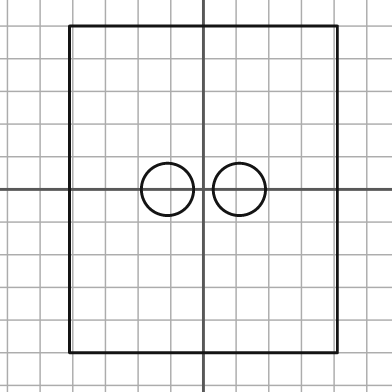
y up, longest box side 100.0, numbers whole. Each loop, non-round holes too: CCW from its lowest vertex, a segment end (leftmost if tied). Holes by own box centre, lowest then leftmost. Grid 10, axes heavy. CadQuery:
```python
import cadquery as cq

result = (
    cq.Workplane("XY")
    .moveTo(-41.0, -50.0)
    .lineTo(41.0, -50.0)
    .lineTo(41.0, 50.0)
    .lineTo(-41.0, 50.0)
    .close()
    .moveTo(-11.0, 0.0)
    .circle(8.0)
    .moveTo(11.0, 0.0)
    .circle(8.0)
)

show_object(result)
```